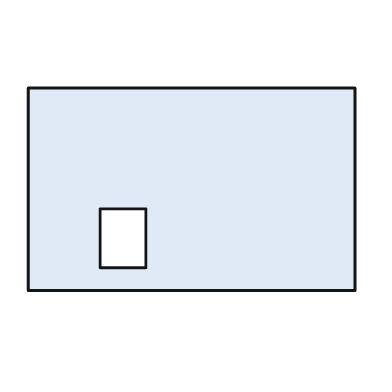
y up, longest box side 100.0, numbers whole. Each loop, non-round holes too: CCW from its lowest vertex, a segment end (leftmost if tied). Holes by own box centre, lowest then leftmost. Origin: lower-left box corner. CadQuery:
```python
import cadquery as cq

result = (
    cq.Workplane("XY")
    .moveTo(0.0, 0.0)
    .lineTo(100.0, 0.0)
    .lineTo(100.0, 62.0)
    .lineTo(0.0, 62.0)
    .close()
    .moveTo(22.0, 7.0)
    .lineTo(36.0, 7.0)
    .lineTo(36.0, 25.0)
    .lineTo(22.0, 25.0)
    .close()
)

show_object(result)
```